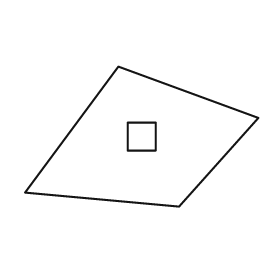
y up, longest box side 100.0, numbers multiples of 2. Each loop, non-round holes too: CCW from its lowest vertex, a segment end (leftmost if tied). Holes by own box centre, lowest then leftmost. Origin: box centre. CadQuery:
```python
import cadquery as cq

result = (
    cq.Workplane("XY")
    .moveTo(16.0, -30.0)
    .lineTo(50.0, 8.0)
    .lineTo(-10.0, 30.0)
    .lineTo(-50.0, -24.0)
    .close()
    .moveTo(-6.0, -6.0)
    .lineTo(6.0, -6.0)
    .lineTo(6.0, 6.0)
    .lineTo(-6.0, 6.0)
    .close()
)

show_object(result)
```